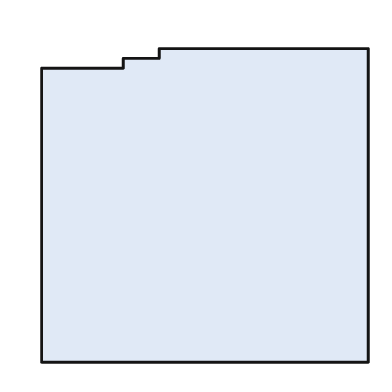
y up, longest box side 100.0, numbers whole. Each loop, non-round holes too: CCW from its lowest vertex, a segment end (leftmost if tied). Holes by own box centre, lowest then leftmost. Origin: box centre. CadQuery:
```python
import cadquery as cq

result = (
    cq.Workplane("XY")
    .moveTo(-50.0, -48.0)
    .lineTo(50.0, -48.0)
    .lineTo(50.0, 48.0)
    .lineTo(-14.0, 48.0)
    .lineTo(-14.0, 45.0)
    .lineTo(-25.0, 45.0)
    .lineTo(-25.0, 42.0)
    .lineTo(-50.0, 42.0)
    .close()
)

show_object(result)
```